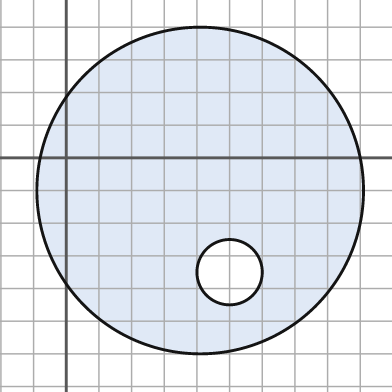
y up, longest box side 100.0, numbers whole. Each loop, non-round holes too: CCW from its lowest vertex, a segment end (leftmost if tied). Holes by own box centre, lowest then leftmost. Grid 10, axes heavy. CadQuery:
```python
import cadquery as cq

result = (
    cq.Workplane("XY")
    .moveTo(41.0, -10.0)
    .circle(50.0)
    .moveTo(50.0, -35.0)
    .circle(10.0)
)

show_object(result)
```